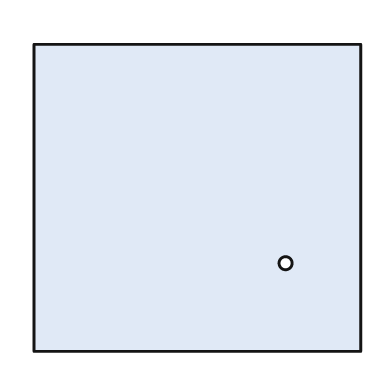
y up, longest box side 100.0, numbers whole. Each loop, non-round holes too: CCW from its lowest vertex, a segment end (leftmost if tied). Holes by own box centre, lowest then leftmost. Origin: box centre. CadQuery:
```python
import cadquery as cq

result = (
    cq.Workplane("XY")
    .moveTo(-50.0, -47.0)
    .lineTo(50.0, -47.0)
    .lineTo(50.0, 47.0)
    .lineTo(-50.0, 47.0)
    .close()
    .moveTo(27.0, -20.0)
    .circle(2.0)
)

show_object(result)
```